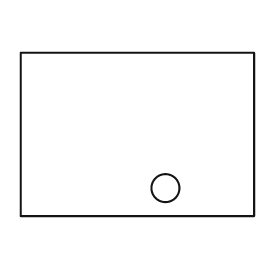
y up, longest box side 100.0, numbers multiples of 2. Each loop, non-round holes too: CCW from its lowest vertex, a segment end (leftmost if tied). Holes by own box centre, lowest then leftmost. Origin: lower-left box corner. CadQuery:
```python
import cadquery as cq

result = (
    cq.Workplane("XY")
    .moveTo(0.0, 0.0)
    .lineTo(100.0, 0.0)
    .lineTo(100.0, 70.0)
    .lineTo(0.0, 70.0)
    .close()
    .moveTo(62.0, 12.0)
    .circle(6.0)
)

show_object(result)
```